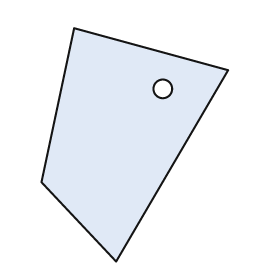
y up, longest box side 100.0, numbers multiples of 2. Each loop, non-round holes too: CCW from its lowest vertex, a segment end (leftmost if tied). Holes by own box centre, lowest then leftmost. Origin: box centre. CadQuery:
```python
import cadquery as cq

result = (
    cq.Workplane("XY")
    .moveTo(-8.0, -50.0)
    .lineTo(40.0, 32.0)
    .lineTo(-26.0, 50.0)
    .lineTo(-40.0, -16.0)
    .close()
    .moveTo(12.0, 24.0)
    .circle(4.0)
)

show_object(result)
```